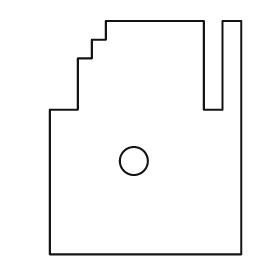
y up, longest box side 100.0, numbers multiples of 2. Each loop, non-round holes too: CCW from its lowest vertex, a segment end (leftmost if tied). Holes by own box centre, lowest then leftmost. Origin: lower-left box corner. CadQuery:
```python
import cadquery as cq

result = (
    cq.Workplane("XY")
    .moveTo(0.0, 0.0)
    .lineTo(82.0, 0.0)
    .lineTo(82.0, 100.0)
    .lineTo(74.0, 100.0)
    .lineTo(74.0, 62.0)
    .lineTo(66.0, 62.0)
    .lineTo(66.0, 100.0)
    .lineTo(24.0, 100.0)
    .lineTo(24.0, 92.0)
    .lineTo(18.0, 92.0)
    .lineTo(18.0, 84.0)
    .lineTo(12.0, 84.0)
    .lineTo(12.0, 62.0)
    .lineTo(0.0, 62.0)
    .close()
    .moveTo(36.0, 40.0)
    .circle(6.0)
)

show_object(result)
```